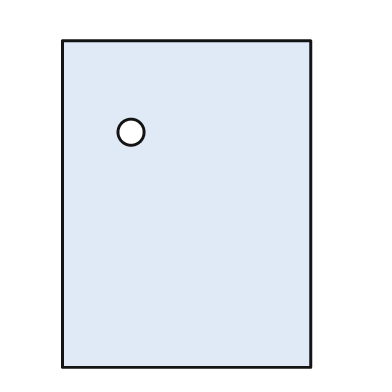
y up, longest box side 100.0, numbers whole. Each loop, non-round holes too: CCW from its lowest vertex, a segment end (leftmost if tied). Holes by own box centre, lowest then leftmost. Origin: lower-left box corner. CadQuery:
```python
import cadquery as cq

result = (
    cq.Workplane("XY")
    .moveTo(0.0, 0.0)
    .lineTo(76.0, 0.0)
    .lineTo(76.0, 100.0)
    .lineTo(0.0, 100.0)
    .close()
    .moveTo(21.0, 72.0)
    .circle(4.0)
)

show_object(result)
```